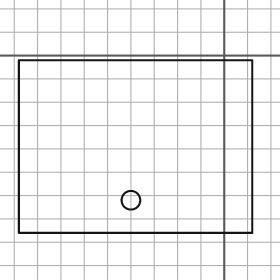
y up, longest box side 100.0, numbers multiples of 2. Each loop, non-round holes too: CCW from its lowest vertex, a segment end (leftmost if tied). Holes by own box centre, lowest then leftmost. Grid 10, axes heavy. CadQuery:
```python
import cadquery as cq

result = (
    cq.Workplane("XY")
    .moveTo(-88.0, -76.0)
    .lineTo(12.0, -76.0)
    .lineTo(12.0, -2.0)
    .lineTo(-88.0, -2.0)
    .close()
    .moveTo(-40.0, -62.0)
    .circle(4.0)
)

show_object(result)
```